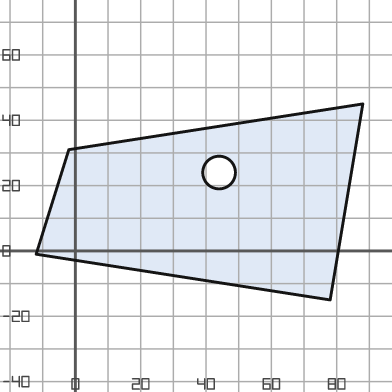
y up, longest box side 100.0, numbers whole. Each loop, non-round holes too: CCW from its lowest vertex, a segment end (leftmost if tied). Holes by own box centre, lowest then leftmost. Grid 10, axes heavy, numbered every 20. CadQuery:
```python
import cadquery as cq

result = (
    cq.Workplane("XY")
    .moveTo(78.0, -15.0)
    .lineTo(88.0, 45.0)
    .lineTo(-2.0, 31.0)
    .lineTo(-12.0, -1.0)
    .close()
    .moveTo(44.0, 24.0)
    .circle(5.0)
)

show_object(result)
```